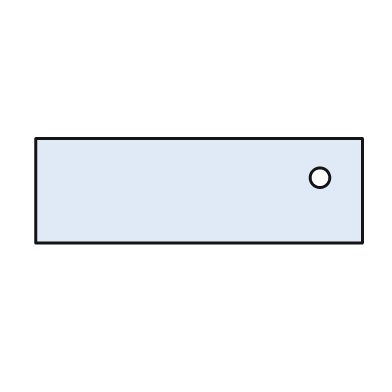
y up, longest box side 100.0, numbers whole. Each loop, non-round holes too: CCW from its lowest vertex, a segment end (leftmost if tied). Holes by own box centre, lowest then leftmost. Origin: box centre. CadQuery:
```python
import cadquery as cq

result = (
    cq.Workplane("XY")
    .moveTo(-50.0, -16.0)
    .lineTo(50.0, -16.0)
    .lineTo(50.0, 16.0)
    .lineTo(-50.0, 16.0)
    .close()
    .moveTo(37.0, 4.0)
    .circle(3.0)
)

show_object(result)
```